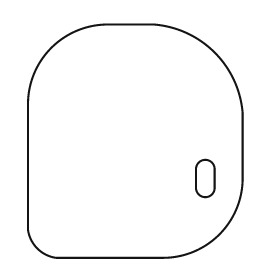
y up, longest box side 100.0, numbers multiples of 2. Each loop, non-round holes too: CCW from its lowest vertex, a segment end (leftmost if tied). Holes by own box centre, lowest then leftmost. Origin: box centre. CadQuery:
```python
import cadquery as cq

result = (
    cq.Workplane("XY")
    .moveTo(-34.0, -50.0)
    .lineTo(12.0, -50.0)
    .threePointArc((36.0, -40.0), (46.0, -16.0))
    .lineTo(46.0, 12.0)
    .threePointArc((34.0, 38.0), (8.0, 50.0))
    .lineTo(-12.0, 50.0)
    .threePointArc((-36.0, 40.0), (-46.0, 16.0))
    .lineTo(-46.0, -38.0)
    .threePointArc((-42.0, -46.0), (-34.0, -50.0))
    .close()
    .moveTo(26.0, -20.0)
    .threePointArc((30.0, -24.0), (34.0, -20.0))
    .lineTo(34.0, -12.0)
    .threePointArc((30.0, -8.0), (26.0, -12.0))
    .close()
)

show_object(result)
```